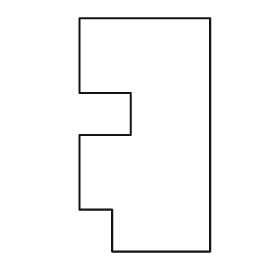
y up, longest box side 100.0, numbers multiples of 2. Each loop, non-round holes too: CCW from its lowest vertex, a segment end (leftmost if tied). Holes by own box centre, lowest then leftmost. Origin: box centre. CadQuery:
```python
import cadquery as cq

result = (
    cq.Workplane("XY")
    .moveTo(-14.0, -50.0)
    .lineTo(28.0, -50.0)
    .lineTo(28.0, 50.0)
    .lineTo(-28.0, 50.0)
    .lineTo(-28.0, 18.0)
    .lineTo(-6.0, 18.0)
    .lineTo(-6.0, 0.0)
    .lineTo(-28.0, 0.0)
    .lineTo(-28.0, -32.0)
    .lineTo(-14.0, -32.0)
    .close()
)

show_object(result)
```